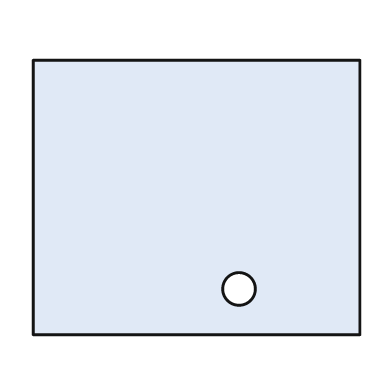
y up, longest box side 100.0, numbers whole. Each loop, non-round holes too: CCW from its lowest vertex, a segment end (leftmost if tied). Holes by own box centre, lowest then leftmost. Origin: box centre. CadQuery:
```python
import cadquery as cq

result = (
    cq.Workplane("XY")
    .moveTo(-50.0, -42.0)
    .lineTo(50.0, -42.0)
    .lineTo(50.0, 42.0)
    .lineTo(-50.0, 42.0)
    .close()
    .moveTo(13.0, -28.0)
    .circle(5.0)
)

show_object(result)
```